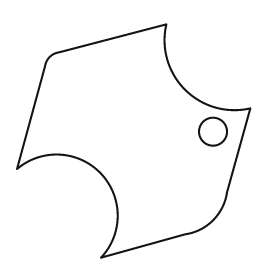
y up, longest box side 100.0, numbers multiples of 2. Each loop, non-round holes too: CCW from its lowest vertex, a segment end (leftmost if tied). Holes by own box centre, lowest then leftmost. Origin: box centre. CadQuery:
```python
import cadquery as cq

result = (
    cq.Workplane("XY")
    .moveTo(-14.0, -50.0)
    .lineTo(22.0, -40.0)
    .threePointArc((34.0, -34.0), (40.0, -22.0))
    .lineTo(50.0, 14.0)
    .threePointArc((22.0, 22.0), (14.0, 50.0))
    .lineTo(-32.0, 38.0)
    .threePointArc((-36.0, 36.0), (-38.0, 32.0))
    .lineTo(-50.0, -12.0)
    .threePointArc((-14.0, -14.0), (-14.0, -50.0))
    .close()
    .moveTo(34.0, 4.0)
    .circle(6.0)
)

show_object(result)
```